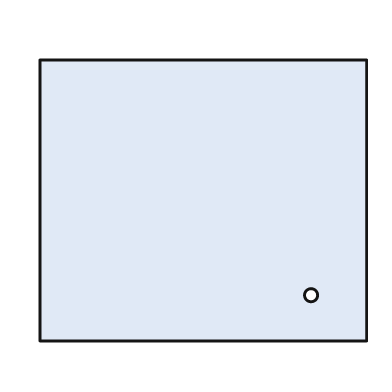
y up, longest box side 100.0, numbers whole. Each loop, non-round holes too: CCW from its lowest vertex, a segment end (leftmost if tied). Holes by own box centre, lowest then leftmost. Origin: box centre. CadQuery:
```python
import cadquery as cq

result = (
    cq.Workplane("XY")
    .moveTo(-50.0, -43.0)
    .lineTo(50.0, -43.0)
    .lineTo(50.0, 43.0)
    .lineTo(-50.0, 43.0)
    .close()
    .moveTo(33.0, -29.0)
    .circle(2.0)
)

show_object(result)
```